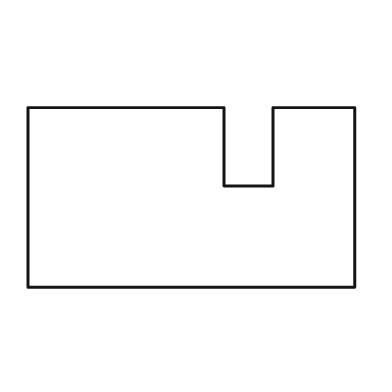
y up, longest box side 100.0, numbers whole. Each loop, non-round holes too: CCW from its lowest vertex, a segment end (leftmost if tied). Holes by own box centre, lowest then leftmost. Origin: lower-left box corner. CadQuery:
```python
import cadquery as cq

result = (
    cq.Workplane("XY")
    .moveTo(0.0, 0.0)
    .lineTo(100.0, 0.0)
    .lineTo(100.0, 55.0)
    .lineTo(75.0, 55.0)
    .lineTo(75.0, 31.0)
    .lineTo(60.0, 31.0)
    .lineTo(60.0, 55.0)
    .lineTo(0.0, 55.0)
    .close()
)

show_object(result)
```